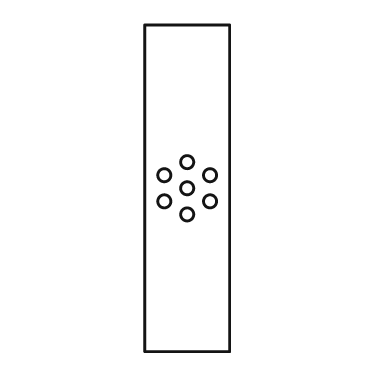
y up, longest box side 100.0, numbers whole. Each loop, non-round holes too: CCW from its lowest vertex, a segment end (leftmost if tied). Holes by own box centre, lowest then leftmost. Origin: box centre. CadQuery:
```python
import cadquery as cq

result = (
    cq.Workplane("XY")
    .moveTo(-13.0, -50.0)
    .lineTo(13.0, -50.0)
    .lineTo(13.0, 50.0)
    .lineTo(-13.0, 50.0)
    .close()
    .moveTo(0.0, -8.0)
    .circle(2.0)
    .moveTo(-7.0, -4.0)
    .circle(2.0)
    .moveTo(7.0, -4.0)
    .circle(2.0)
    .moveTo(0.0, 0.0)
    .circle(2.0)
    .moveTo(-7.0, 4.0)
    .circle(2.0)
    .moveTo(7.0, 4.0)
    .circle(2.0)
    .moveTo(0.0, 8.0)
    .circle(2.0)
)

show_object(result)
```